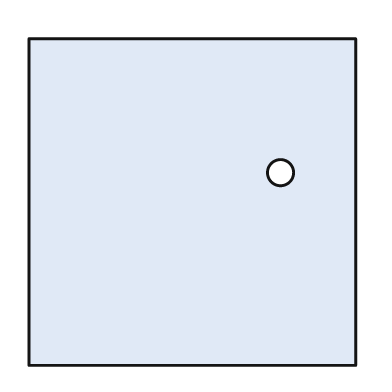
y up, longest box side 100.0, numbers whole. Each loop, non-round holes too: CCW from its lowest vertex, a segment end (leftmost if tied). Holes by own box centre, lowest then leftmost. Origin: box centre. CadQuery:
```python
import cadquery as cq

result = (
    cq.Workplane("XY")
    .moveTo(-50.0, -50.0)
    .lineTo(50.0, -50.0)
    .lineTo(50.0, 50.0)
    .lineTo(-50.0, 50.0)
    .close()
    .moveTo(27.0, 9.0)
    .circle(4.0)
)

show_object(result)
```